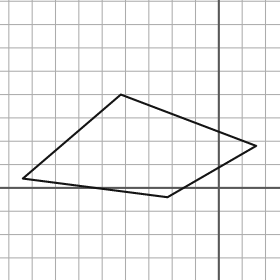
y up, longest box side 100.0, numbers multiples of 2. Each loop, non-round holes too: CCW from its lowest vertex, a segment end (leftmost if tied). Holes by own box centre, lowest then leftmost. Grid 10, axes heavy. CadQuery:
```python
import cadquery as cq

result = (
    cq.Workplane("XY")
    .moveTo(-22.0, -4.0)
    .lineTo(16.0, 18.0)
    .lineTo(-42.0, 40.0)
    .lineTo(-84.0, 4.0)
    .close()
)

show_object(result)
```